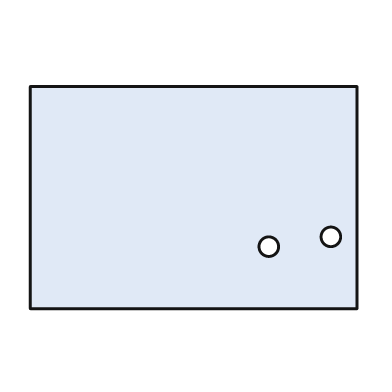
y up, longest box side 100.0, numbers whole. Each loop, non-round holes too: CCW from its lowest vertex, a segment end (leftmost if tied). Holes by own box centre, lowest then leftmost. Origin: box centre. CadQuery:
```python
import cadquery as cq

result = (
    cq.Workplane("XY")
    .moveTo(-50.0, -34.0)
    .lineTo(50.0, -34.0)
    .lineTo(50.0, 34.0)
    .lineTo(-50.0, 34.0)
    .close()
    .moveTo(23.0, -15.0)
    .circle(3.0)
    .moveTo(42.0, -12.0)
    .circle(3.0)
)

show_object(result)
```